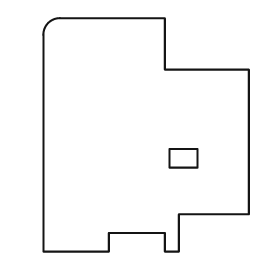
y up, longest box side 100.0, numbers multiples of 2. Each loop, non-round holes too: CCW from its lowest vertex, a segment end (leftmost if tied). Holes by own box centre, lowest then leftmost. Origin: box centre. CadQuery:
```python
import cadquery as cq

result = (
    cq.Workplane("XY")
    .moveTo(-44.0, -50.0)
    .lineTo(-16.0, -50.0)
    .lineTo(-16.0, -42.0)
    .lineTo(8.0, -42.0)
    .lineTo(8.0, -50.0)
    .lineTo(14.0, -50.0)
    .lineTo(14.0, -34.0)
    .lineTo(44.0, -34.0)
    .lineTo(44.0, 28.0)
    .lineTo(8.0, 28.0)
    .lineTo(8.0, 50.0)
    .lineTo(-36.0, 50.0)
    .threePointArc((-42.0, 48.0), (-44.0, 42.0))
    .close()
    .moveTo(10.0, -14.0)
    .lineTo(22.0, -14.0)
    .lineTo(22.0, -6.0)
    .lineTo(10.0, -6.0)
    .close()
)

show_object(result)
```